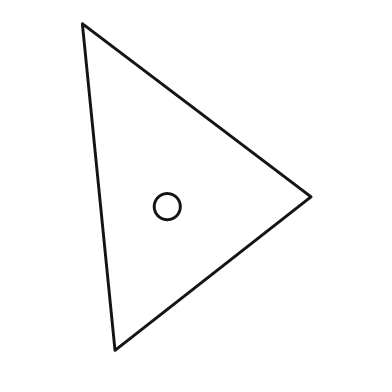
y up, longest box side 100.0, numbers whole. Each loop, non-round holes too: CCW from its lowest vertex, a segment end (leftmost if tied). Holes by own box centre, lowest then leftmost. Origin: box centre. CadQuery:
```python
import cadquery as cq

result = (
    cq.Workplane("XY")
    .moveTo(-25.0, -50.0)
    .lineTo(35.0, -3.0)
    .lineTo(-35.0, 50.0)
    .close()
    .moveTo(-9.0, -6.0)
    .circle(4.0)
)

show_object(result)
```